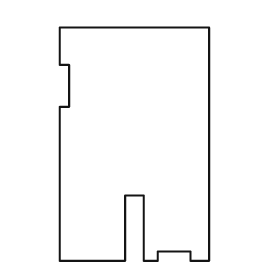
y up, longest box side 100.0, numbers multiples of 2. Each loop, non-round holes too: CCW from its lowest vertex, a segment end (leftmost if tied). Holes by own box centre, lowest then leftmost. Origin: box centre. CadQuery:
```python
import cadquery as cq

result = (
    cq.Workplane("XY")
    .moveTo(-32.0, -50.0)
    .lineTo(-4.0, -50.0)
    .lineTo(-4.0, -22.0)
    .lineTo(4.0, -22.0)
    .lineTo(4.0, -50.0)
    .lineTo(10.0, -50.0)
    .lineTo(10.0, -46.0)
    .lineTo(24.0, -46.0)
    .lineTo(24.0, -50.0)
    .lineTo(32.0, -50.0)
    .lineTo(32.0, 50.0)
    .lineTo(-32.0, 50.0)
    .lineTo(-32.0, 34.0)
    .lineTo(-28.0, 34.0)
    .lineTo(-28.0, 16.0)
    .lineTo(-32.0, 16.0)
    .close()
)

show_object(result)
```